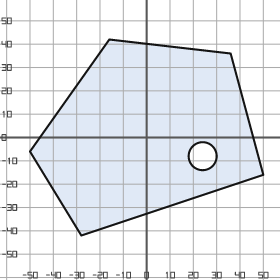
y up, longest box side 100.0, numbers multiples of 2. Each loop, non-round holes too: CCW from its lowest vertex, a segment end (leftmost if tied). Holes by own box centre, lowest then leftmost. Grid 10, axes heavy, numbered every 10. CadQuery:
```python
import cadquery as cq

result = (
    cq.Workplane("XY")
    .moveTo(-28.0, -42.0)
    .lineTo(50.0, -16.0)
    .lineTo(36.0, 36.0)
    .lineTo(-16.0, 42.0)
    .lineTo(-50.0, -6.0)
    .close()
    .moveTo(24.0, -8.0)
    .circle(6.0)
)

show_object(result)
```